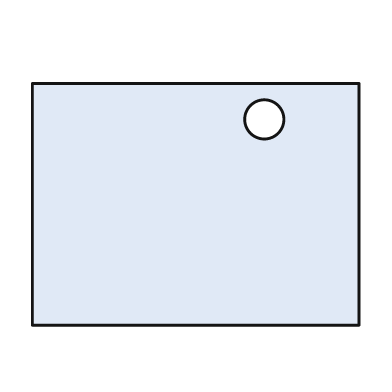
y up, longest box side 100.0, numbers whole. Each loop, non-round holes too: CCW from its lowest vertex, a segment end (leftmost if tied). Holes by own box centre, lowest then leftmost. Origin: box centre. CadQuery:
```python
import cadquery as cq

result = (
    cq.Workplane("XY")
    .moveTo(-50.0, -37.0)
    .lineTo(50.0, -37.0)
    .lineTo(50.0, 37.0)
    .lineTo(-50.0, 37.0)
    .close()
    .moveTo(21.0, 26.0)
    .circle(6.0)
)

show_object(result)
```